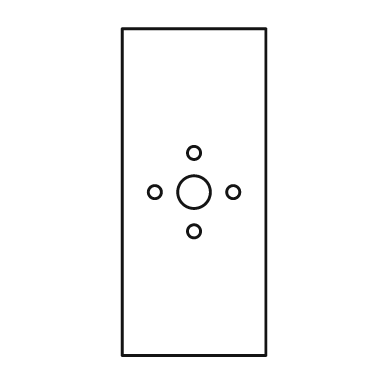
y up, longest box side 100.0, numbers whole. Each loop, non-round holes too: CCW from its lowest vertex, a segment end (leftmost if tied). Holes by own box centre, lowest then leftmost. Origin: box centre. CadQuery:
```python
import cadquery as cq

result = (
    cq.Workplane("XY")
    .moveTo(-22.0, -50.0)
    .lineTo(22.0, -50.0)
    .lineTo(22.0, 50.0)
    .lineTo(-22.0, 50.0)
    .close()
    .moveTo(0.0, -12.0)
    .circle(2.0)
    .moveTo(-12.0, 0.0)
    .circle(2.0)
    .moveTo(0.0, 0.0)
    .circle(5.0)
    .moveTo(12.0, 0.0)
    .circle(2.0)
    .moveTo(0.0, 12.0)
    .circle(2.0)
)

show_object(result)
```